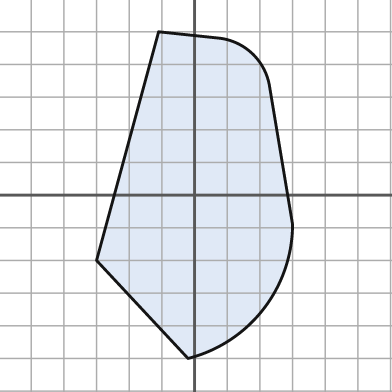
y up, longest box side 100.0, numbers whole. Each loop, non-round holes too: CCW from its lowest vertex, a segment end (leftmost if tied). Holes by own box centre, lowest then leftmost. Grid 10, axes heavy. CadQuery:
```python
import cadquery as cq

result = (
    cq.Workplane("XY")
    .moveTo(-2.0, -50.0)
    .threePointArc((21.0, -35.0), (30.0, -9.0))
    .lineTo(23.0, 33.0)
    .threePointArc((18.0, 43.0), (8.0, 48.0))
    .lineTo(-11.0, 50.0)
    .lineTo(-30.0, -20.0)
    .close()
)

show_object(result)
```